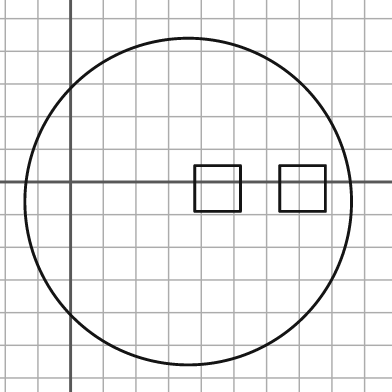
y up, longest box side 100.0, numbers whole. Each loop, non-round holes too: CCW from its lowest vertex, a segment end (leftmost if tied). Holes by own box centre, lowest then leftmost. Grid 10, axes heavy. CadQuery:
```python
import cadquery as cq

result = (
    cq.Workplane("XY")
    .moveTo(36.0, -6.0)
    .circle(50.0)
    .moveTo(38.0, -9.0)
    .lineTo(52.0, -9.0)
    .lineTo(52.0, 5.0)
    .lineTo(38.0, 5.0)
    .close()
    .moveTo(64.0, -9.0)
    .lineTo(78.0, -9.0)
    .lineTo(78.0, 5.0)
    .lineTo(64.0, 5.0)
    .close()
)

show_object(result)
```